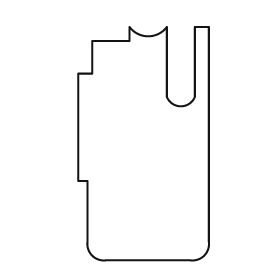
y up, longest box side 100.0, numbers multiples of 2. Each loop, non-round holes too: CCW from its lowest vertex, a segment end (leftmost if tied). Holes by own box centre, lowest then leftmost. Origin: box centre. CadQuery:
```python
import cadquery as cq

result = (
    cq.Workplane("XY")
    .moveTo(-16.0, -50.0)
    .lineTo(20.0, -50.0)
    .threePointArc((26.0, -48.0), (28.0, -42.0))
    .lineTo(28.0, 50.0)
    .lineTo(22.0, 50.0)
    .lineTo(22.0, 20.0)
    .threePointArc((16.0, 16.0), (10.0, 20.0))
    .lineTo(10.0, 50.0)
    .threePointArc((2.0, 46.0), (-6.0, 50.0))
    .lineTo(-6.0, 44.0)
    .lineTo(-22.0, 44.0)
    .lineTo(-22.0, 30.0)
    .lineTo(-28.0, 30.0)
    .lineTo(-28.0, -16.0)
    .lineTo(-24.0, -16.0)
    .lineTo(-24.0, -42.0)
    .threePointArc((-22.0, -48.0), (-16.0, -50.0))
    .close()
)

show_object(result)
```